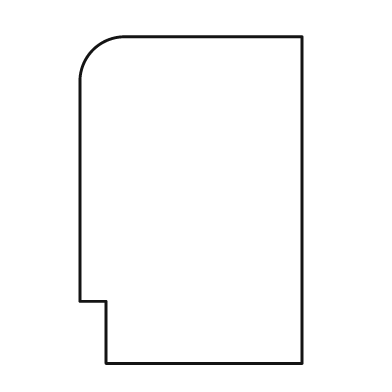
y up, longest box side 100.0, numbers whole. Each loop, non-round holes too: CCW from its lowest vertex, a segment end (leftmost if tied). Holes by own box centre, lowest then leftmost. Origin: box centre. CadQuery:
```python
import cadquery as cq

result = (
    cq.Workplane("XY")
    .moveTo(-26.0, -50.0)
    .lineTo(34.0, -50.0)
    .lineTo(34.0, 50.0)
    .lineTo(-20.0, 50.0)
    .threePointArc((-30.0, 46.0), (-34.0, 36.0))
    .lineTo(-34.0, -31.0)
    .lineTo(-26.0, -31.0)
    .close()
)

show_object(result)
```